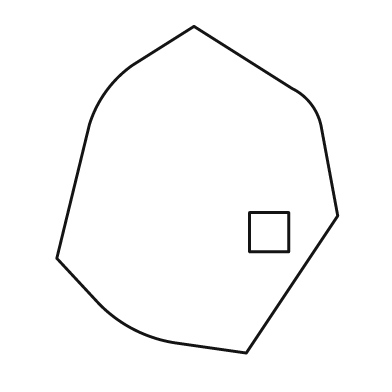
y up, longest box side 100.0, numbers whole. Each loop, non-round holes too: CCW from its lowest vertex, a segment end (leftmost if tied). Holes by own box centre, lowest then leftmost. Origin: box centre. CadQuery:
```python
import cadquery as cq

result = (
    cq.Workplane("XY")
    .moveTo(15.0, -50.0)
    .lineTo(43.0, -8.0)
    .lineTo(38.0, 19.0)
    .threePointArc((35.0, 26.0), (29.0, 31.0))
    .lineTo(-1.0, 50.0)
    .lineTo(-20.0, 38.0)
    .threePointArc((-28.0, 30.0), (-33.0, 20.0))
    .lineTo(-43.0, -21.0)
    .lineTo(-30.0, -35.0)
    .threePointArc((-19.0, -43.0), (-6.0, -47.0))
    .close()
    .moveTo(16.0, -19.0)
    .lineTo(28.0, -19.0)
    .lineTo(28.0, -7.0)
    .lineTo(16.0, -7.0)
    .close()
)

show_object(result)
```